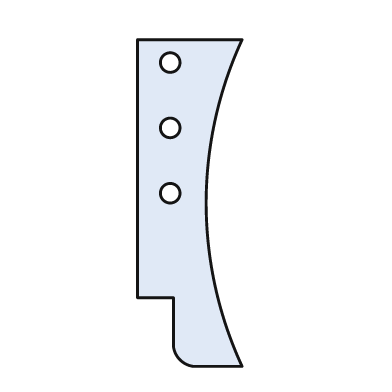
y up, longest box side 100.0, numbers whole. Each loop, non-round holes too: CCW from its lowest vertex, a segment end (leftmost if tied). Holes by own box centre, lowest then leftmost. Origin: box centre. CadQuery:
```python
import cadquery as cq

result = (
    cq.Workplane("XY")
    .moveTo(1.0, -50.0)
    .lineTo(16.0, -50.0)
    .threePointArc((5.0, 0.0), (16.0, 50.0))
    .lineTo(-16.0, 50.0)
    .lineTo(-16.0, -29.0)
    .lineTo(-5.0, -29.0)
    .lineTo(-5.0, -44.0)
    .threePointArc((-3.0, -48.0), (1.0, -50.0))
    .close()
    .moveTo(-6.0, 3.0)
    .circle(3.0)
    .moveTo(-6.0, 23.0)
    .circle(3.0)
    .moveTo(-6.0, 43.0)
    .circle(3.0)
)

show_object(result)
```